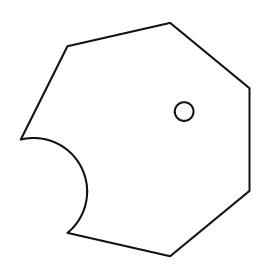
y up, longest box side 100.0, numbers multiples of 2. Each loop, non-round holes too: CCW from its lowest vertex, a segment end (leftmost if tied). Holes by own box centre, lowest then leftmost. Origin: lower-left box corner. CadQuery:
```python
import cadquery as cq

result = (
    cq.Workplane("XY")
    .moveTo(64.0, 0.0)
    .lineTo(98.0, 28.0)
    .lineTo(98.0, 72.0)
    .lineTo(64.0, 100.0)
    .lineTo(20.0, 90.0)
    .lineTo(0.0, 50.0)
    .threePointArc((26.0, 38.0), (20.0, 10.0))
    .close()
    .moveTo(70.0, 62.0)
    .circle(4.0)
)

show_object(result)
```